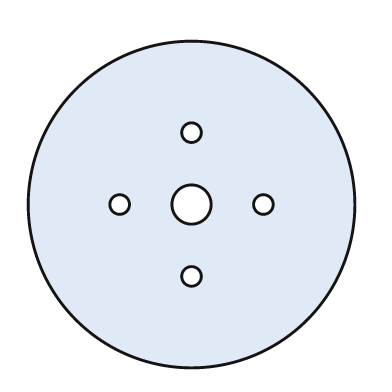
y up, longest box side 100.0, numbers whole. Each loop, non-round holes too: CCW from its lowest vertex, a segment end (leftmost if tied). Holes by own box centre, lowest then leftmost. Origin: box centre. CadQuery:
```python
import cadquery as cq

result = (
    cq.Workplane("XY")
    .moveTo(0.0, 0.0)
    .circle(50.0)
    .moveTo(0.0, -22.0)
    .circle(3.0)
    .moveTo(-22.0, 0.0)
    .circle(3.0)
    .moveTo(0.0, 0.0)
    .circle(6.0)
    .moveTo(22.0, 0.0)
    .circle(3.0)
    .moveTo(0.0, 22.0)
    .circle(3.0)
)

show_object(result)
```